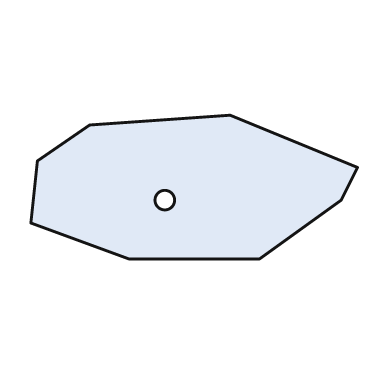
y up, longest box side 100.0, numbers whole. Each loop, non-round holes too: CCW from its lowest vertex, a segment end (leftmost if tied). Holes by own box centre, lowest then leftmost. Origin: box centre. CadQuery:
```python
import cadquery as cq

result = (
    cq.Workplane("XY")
    .moveTo(-20.0, -22.0)
    .lineTo(20.0, -22.0)
    .lineTo(45.0, -4.0)
    .lineTo(50.0, 6.0)
    .lineTo(11.0, 22.0)
    .lineTo(-32.0, 19.0)
    .lineTo(-48.0, 8.0)
    .lineTo(-50.0, -11.0)
    .close()
    .moveTo(-9.0, -4.0)
    .circle(3.0)
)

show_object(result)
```